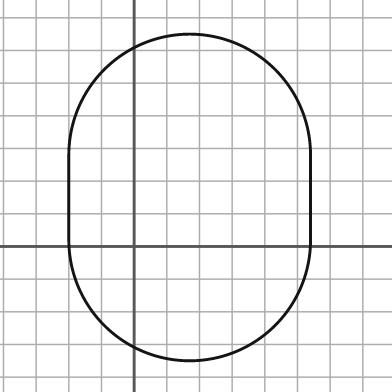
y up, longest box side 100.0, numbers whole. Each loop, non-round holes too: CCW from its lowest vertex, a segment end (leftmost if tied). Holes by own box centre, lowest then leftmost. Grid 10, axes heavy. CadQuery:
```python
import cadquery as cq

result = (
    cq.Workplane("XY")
    .moveTo(-20.0, 2.0)
    .threePointArc((17.0, -35.0), (54.0, 2.0))
    .lineTo(54.0, 28.0)
    .threePointArc((17.0, 65.0), (-20.0, 28.0))
    .close()
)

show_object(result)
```